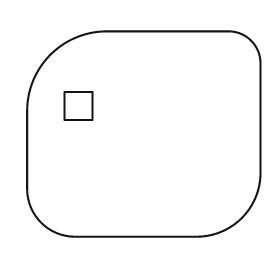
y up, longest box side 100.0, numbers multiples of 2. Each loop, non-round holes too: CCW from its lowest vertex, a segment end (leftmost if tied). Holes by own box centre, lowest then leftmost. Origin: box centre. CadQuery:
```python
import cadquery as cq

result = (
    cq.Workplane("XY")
    .moveTo(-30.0, -44.0)
    .lineTo(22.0, -44.0)
    .threePointArc((42.0, -36.0), (50.0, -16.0))
    .lineTo(50.0, 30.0)
    .threePointArc((46.0, 40.0), (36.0, 44.0))
    .lineTo(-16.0, 44.0)
    .threePointArc((-40.0, 34.0), (-50.0, 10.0))
    .lineTo(-50.0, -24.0)
    .threePointArc((-44.0, -38.0), (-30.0, -44.0))
    .close()
    .moveTo(-34.0, 6.0)
    .lineTo(-22.0, 6.0)
    .lineTo(-22.0, 18.0)
    .lineTo(-34.0, 18.0)
    .close()
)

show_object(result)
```